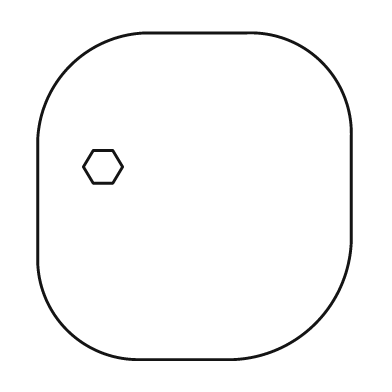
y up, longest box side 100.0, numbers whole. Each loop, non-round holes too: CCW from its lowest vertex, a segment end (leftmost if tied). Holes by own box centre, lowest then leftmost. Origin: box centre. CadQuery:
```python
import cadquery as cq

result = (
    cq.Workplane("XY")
    .moveTo(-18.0, -50.0)
    .lineTo(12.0, -50.0)
    .threePointArc((37.0, -39.0), (48.0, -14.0))
    .lineTo(48.0, 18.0)
    .threePointArc((39.0, 41.0), (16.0, 50.0))
    .lineTo(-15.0, 50.0)
    .threePointArc((-38.0, 40.0), (-48.0, 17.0))
    .lineTo(-48.0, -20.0)
    .threePointArc((-39.0, -41.0), (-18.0, -50.0))
    .close()
    .moveTo(-31.0, 4.0)
    .lineTo(-25.0, 4.0)
    .lineTo(-22.0, 9.0)
    .lineTo(-25.0, 14.0)
    .lineTo(-31.0, 14.0)
    .lineTo(-34.0, 9.0)
    .close()
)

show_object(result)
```